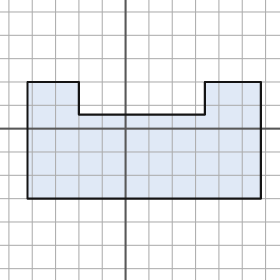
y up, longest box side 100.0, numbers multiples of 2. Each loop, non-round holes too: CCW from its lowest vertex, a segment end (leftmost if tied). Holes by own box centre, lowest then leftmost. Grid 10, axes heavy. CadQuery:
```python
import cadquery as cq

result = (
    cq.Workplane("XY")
    .moveTo(-42.0, -30.0)
    .lineTo(58.0, -30.0)
    .lineTo(58.0, 20.0)
    .lineTo(34.0, 20.0)
    .lineTo(34.0, 6.0)
    .lineTo(-20.0, 6.0)
    .lineTo(-20.0, 20.0)
    .lineTo(-42.0, 20.0)
    .close()
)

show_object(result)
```